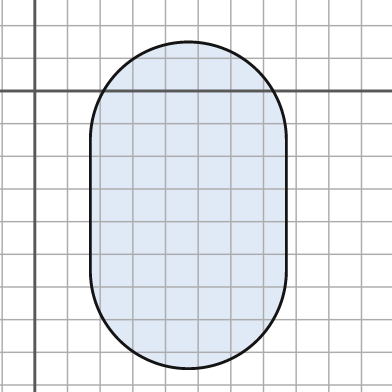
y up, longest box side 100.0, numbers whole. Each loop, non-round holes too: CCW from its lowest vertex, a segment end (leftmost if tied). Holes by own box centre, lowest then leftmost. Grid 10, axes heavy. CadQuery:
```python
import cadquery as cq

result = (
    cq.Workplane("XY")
    .moveTo(17.0, -55.0)
    .threePointArc((47.0, -85.0), (77.0, -55.0))
    .lineTo(77.0, -15.0)
    .threePointArc((47.0, 15.0), (17.0, -15.0))
    .close()
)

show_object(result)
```